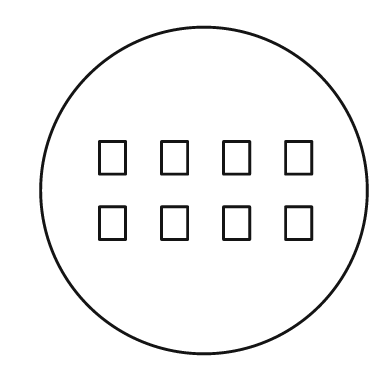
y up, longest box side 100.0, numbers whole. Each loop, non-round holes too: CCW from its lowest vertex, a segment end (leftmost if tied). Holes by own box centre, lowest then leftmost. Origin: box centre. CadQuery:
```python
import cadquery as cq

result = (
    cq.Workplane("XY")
    .moveTo(0.0, 0.0)
    .circle(50.0)
    .moveTo(-32.0, -15.0)
    .lineTo(-24.0, -15.0)
    .lineTo(-24.0, -5.0)
    .lineTo(-32.0, -5.0)
    .close()
    .moveTo(-13.0, -15.0)
    .lineTo(-5.0, -15.0)
    .lineTo(-5.0, -5.0)
    .lineTo(-13.0, -5.0)
    .close()
    .moveTo(6.0, -15.0)
    .lineTo(14.0, -15.0)
    .lineTo(14.0, -5.0)
    .lineTo(6.0, -5.0)
    .close()
    .moveTo(25.0, -15.0)
    .lineTo(33.0, -15.0)
    .lineTo(33.0, -5.0)
    .lineTo(25.0, -5.0)
    .close()
    .moveTo(-32.0, 5.0)
    .lineTo(-24.0, 5.0)
    .lineTo(-24.0, 15.0)
    .lineTo(-32.0, 15.0)
    .close()
    .moveTo(-13.0, 5.0)
    .lineTo(-5.0, 5.0)
    .lineTo(-5.0, 15.0)
    .lineTo(-13.0, 15.0)
    .close()
    .moveTo(6.0, 5.0)
    .lineTo(14.0, 5.0)
    .lineTo(14.0, 15.0)
    .lineTo(6.0, 15.0)
    .close()
    .moveTo(25.0, 5.0)
    .lineTo(33.0, 5.0)
    .lineTo(33.0, 15.0)
    .lineTo(25.0, 15.0)
    .close()
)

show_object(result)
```